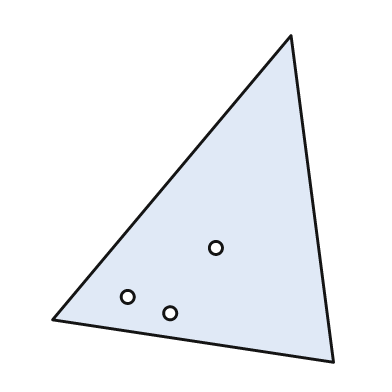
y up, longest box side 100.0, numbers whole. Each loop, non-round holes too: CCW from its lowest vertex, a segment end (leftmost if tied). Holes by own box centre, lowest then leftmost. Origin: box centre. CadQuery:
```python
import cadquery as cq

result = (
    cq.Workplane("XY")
    .moveTo(43.0, -50.0)
    .lineTo(30.0, 50.0)
    .lineTo(-43.0, -37.0)
    .close()
    .moveTo(-7.0, -35.0)
    .circle(2.0)
    .moveTo(-20.0, -30.0)
    .circle(2.0)
    .moveTo(7.0, -15.0)
    .circle(2.0)
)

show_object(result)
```